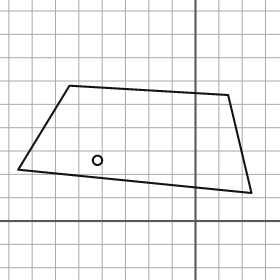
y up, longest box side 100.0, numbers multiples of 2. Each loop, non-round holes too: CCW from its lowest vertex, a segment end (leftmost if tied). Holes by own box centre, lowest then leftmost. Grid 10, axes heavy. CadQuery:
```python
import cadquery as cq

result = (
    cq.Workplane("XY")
    .moveTo(24.0, 12.0)
    .lineTo(14.0, 54.0)
    .lineTo(-54.0, 58.0)
    .lineTo(-76.0, 22.0)
    .close()
    .moveTo(-42.0, 26.0)
    .circle(2.0)
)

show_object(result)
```